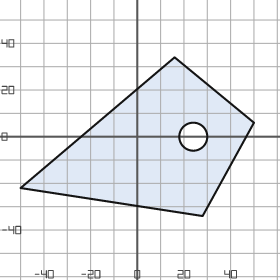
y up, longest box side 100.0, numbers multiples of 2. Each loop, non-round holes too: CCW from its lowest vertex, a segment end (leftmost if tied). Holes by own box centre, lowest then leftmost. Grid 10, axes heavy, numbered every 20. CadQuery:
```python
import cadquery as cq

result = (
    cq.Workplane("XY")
    .moveTo(28.0, -34.0)
    .lineTo(50.0, 6.0)
    .lineTo(16.0, 34.0)
    .lineTo(-50.0, -22.0)
    .close()
    .moveTo(24.0, 0.0)
    .circle(6.0)
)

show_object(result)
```